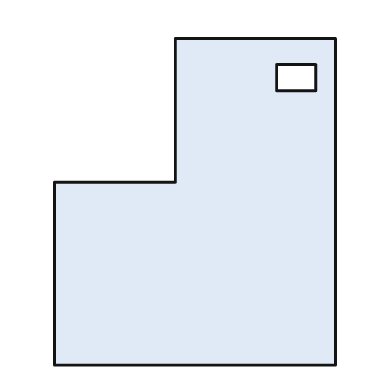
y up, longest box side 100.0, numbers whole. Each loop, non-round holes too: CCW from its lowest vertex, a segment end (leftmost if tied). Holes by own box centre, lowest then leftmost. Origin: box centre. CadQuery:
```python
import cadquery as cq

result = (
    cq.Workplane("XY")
    .moveTo(-43.0, -50.0)
    .lineTo(43.0, -50.0)
    .lineTo(43.0, 50.0)
    .lineTo(-6.0, 50.0)
    .lineTo(-6.0, 6.0)
    .lineTo(-43.0, 6.0)
    .close()
    .moveTo(25.0, 34.0)
    .lineTo(37.0, 34.0)
    .lineTo(37.0, 42.0)
    .lineTo(25.0, 42.0)
    .close()
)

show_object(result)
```